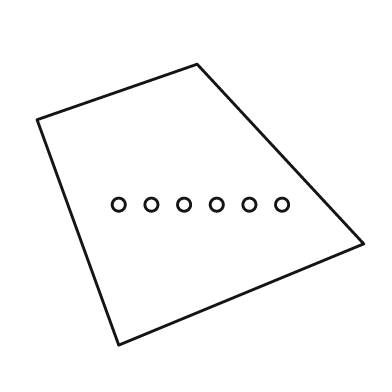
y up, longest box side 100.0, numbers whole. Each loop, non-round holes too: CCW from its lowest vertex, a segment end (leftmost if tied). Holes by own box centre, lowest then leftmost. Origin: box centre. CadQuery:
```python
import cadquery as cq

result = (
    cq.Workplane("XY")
    .moveTo(-25.0, -43.0)
    .lineTo(50.0, -12.0)
    .lineTo(-1.0, 43.0)
    .lineTo(-50.0, 26.0)
    .close()
    .moveTo(-25.0, 0.0)
    .circle(2.0)
    .moveTo(-15.0, 0.0)
    .circle(2.0)
    .moveTo(-5.0, 0.0)
    .circle(2.0)
    .moveTo(5.0, 0.0)
    .circle(2.0)
    .moveTo(15.0, 0.0)
    .circle(2.0)
    .moveTo(25.0, 0.0)
    .circle(2.0)
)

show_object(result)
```